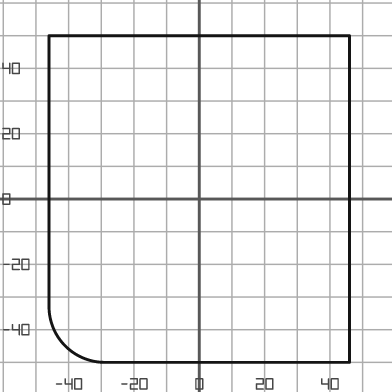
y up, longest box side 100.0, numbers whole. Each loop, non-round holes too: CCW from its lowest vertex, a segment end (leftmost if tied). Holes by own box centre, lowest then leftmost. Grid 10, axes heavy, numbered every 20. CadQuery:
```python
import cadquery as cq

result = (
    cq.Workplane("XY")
    .moveTo(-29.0, -50.0)
    .lineTo(46.0, -50.0)
    .lineTo(46.0, 50.0)
    .lineTo(-46.0, 50.0)
    .lineTo(-46.0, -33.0)
    .threePointArc((-41.0, -45.0), (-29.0, -50.0))
    .close()
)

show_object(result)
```